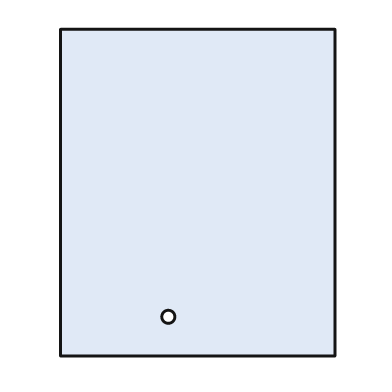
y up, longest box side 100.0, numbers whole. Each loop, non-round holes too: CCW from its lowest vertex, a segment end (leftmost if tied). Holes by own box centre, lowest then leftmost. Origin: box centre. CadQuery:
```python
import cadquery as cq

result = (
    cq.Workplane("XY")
    .moveTo(-42.0, -50.0)
    .lineTo(42.0, -50.0)
    .lineTo(42.0, 50.0)
    .lineTo(-42.0, 50.0)
    .close()
    .moveTo(-9.0, -38.0)
    .circle(2.0)
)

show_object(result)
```